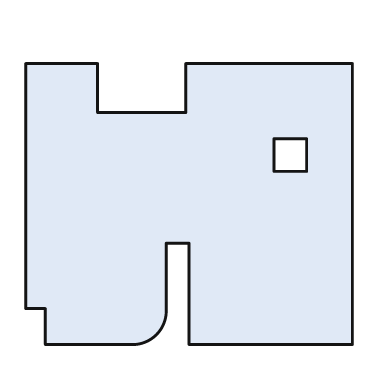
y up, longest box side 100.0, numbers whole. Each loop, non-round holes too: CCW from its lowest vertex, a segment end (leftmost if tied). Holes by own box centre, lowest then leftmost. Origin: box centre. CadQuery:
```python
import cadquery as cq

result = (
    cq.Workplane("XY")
    .moveTo(-44.0, -43.0)
    .lineTo(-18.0, -43.0)
    .threePointArc((-10.0, -40.0), (-7.0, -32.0))
    .lineTo(-7.0, -12.0)
    .lineTo(0.0, -12.0)
    .lineTo(0.0, -43.0)
    .lineTo(50.0, -43.0)
    .lineTo(50.0, 43.0)
    .lineTo(-1.0, 43.0)
    .lineTo(-1.0, 28.0)
    .lineTo(-28.0, 28.0)
    .lineTo(-28.0, 43.0)
    .lineTo(-50.0, 43.0)
    .lineTo(-50.0, -32.0)
    .lineTo(-44.0, -32.0)
    .close()
    .moveTo(26.0, 10.0)
    .lineTo(36.0, 10.0)
    .lineTo(36.0, 20.0)
    .lineTo(26.0, 20.0)
    .close()
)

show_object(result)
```